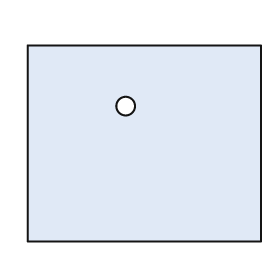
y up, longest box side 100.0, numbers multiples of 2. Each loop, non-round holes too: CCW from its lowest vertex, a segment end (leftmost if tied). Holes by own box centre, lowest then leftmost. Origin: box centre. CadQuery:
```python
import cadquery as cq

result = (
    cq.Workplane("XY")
    .moveTo(-50.0, -42.0)
    .lineTo(50.0, -42.0)
    .lineTo(50.0, 42.0)
    .lineTo(-50.0, 42.0)
    .close()
    .moveTo(-8.0, 16.0)
    .circle(4.0)
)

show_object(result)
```